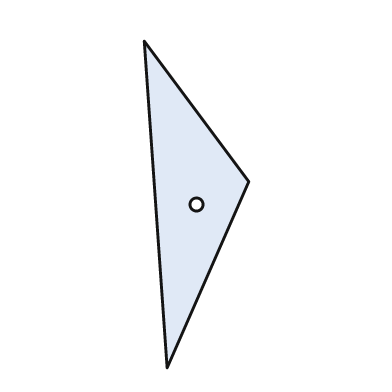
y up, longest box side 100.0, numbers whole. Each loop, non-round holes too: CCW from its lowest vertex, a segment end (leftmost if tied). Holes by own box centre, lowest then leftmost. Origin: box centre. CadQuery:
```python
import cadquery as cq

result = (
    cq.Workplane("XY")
    .moveTo(-9.0, -50.0)
    .lineTo(16.0, 7.0)
    .lineTo(-16.0, 50.0)
    .close()
    .moveTo(0.0, 0.0)
    .circle(2.0)
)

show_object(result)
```